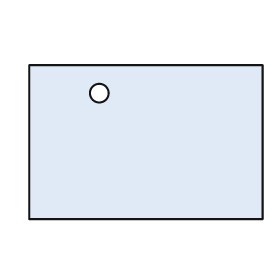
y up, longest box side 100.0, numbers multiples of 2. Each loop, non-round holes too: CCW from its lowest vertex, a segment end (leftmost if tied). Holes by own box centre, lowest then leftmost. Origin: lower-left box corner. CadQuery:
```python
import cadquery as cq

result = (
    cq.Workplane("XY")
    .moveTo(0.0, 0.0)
    .lineTo(100.0, 0.0)
    .lineTo(100.0, 66.0)
    .lineTo(0.0, 66.0)
    .close()
    .moveTo(30.0, 54.0)
    .circle(4.0)
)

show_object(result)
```